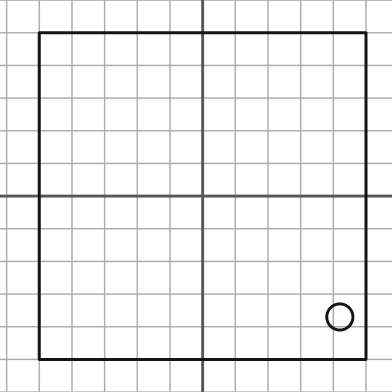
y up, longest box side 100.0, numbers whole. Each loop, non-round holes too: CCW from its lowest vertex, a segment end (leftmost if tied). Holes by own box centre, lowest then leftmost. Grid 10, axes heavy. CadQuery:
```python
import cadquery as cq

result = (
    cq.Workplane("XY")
    .moveTo(-50.0, -50.0)
    .lineTo(50.0, -50.0)
    .lineTo(50.0, 50.0)
    .lineTo(-50.0, 50.0)
    .close()
    .moveTo(42.0, -37.0)
    .circle(4.0)
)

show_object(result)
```